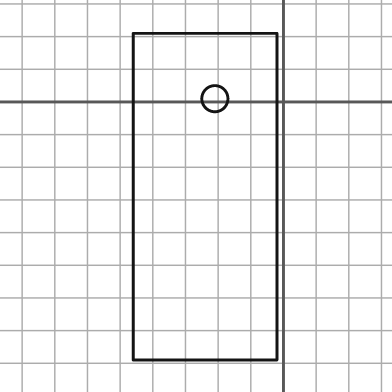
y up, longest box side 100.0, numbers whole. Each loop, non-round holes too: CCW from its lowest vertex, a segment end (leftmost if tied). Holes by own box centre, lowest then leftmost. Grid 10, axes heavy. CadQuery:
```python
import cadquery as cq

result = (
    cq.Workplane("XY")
    .moveTo(-46.0, -79.0)
    .lineTo(-2.0, -79.0)
    .lineTo(-2.0, 21.0)
    .lineTo(-46.0, 21.0)
    .close()
    .moveTo(-21.0, 1.0)
    .circle(4.0)
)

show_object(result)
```